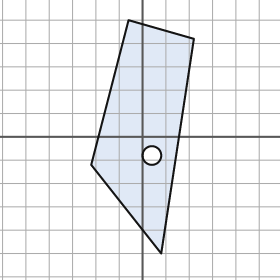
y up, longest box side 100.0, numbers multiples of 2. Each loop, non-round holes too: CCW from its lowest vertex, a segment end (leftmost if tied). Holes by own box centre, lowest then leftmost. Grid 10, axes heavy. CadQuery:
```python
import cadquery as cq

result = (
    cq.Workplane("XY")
    .moveTo(8.0, -50.0)
    .lineTo(22.0, 42.0)
    .lineTo(-6.0, 50.0)
    .lineTo(-22.0, -12.0)
    .close()
    .moveTo(4.0, -8.0)
    .circle(4.0)
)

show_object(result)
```